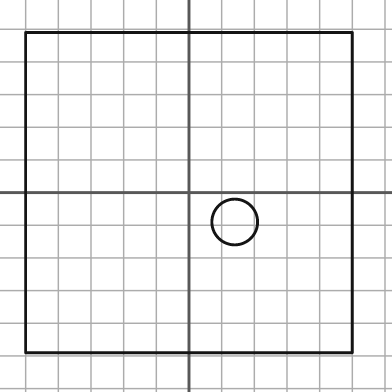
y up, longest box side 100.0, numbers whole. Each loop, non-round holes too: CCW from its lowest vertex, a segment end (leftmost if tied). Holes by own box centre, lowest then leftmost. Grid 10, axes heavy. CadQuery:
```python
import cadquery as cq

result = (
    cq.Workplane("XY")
    .moveTo(-50.0, -49.0)
    .lineTo(50.0, -49.0)
    .lineTo(50.0, 49.0)
    .lineTo(-50.0, 49.0)
    .close()
    .moveTo(14.0, -9.0)
    .circle(7.0)
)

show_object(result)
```